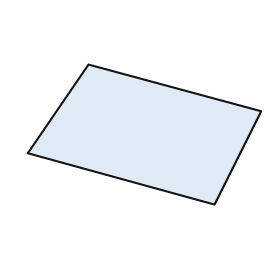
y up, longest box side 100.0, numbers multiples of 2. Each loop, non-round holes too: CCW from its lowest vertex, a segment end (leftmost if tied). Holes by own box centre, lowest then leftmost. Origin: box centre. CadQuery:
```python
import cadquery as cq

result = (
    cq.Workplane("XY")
    .moveTo(30.0, -30.0)
    .lineTo(50.0, 10.0)
    .lineTo(-24.0, 30.0)
    .lineTo(-50.0, -8.0)
    .close()
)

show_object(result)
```